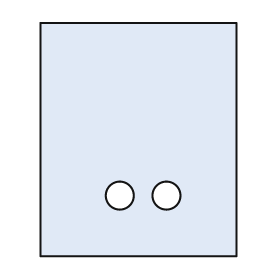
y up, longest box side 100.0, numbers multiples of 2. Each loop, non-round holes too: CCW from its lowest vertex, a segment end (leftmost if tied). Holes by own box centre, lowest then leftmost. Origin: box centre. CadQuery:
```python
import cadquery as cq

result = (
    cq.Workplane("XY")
    .moveTo(-42.0, -50.0)
    .lineTo(42.0, -50.0)
    .lineTo(42.0, 50.0)
    .lineTo(-42.0, 50.0)
    .close()
    .moveTo(-8.0, -24.0)
    .circle(6.0)
    .moveTo(12.0, -24.0)
    .circle(6.0)
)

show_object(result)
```